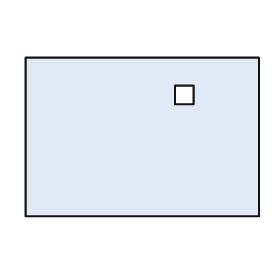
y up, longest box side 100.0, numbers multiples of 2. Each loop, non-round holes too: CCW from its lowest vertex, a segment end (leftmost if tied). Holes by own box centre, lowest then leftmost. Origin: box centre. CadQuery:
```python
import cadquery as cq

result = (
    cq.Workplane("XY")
    .moveTo(-50.0, -34.0)
    .lineTo(50.0, -34.0)
    .lineTo(50.0, 34.0)
    .lineTo(-50.0, 34.0)
    .close()
    .moveTo(14.0, 14.0)
    .lineTo(22.0, 14.0)
    .lineTo(22.0, 22.0)
    .lineTo(14.0, 22.0)
    .close()
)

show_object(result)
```